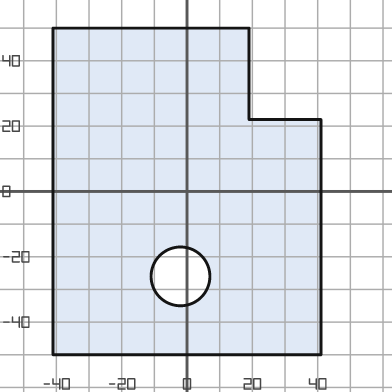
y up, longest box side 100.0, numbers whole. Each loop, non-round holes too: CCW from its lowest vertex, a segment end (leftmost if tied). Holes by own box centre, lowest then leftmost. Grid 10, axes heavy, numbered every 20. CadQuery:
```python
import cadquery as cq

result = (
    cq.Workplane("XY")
    .moveTo(-41.0, -50.0)
    .lineTo(41.0, -50.0)
    .lineTo(41.0, 22.0)
    .lineTo(19.0, 22.0)
    .lineTo(19.0, 50.0)
    .lineTo(-41.0, 50.0)
    .close()
    .moveTo(-2.0, -26.0)
    .circle(9.0)
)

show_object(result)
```